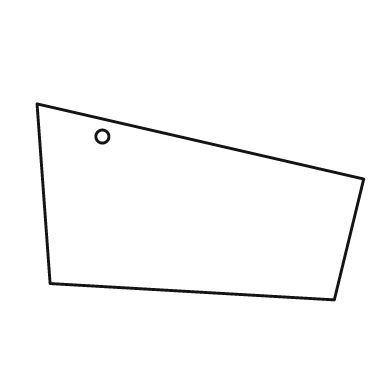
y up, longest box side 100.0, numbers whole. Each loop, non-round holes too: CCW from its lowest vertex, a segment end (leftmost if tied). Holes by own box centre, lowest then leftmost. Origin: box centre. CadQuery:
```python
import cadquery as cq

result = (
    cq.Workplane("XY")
    .moveTo(41.0, -30.0)
    .lineTo(50.0, 7.0)
    .lineTo(-50.0, 30.0)
    .lineTo(-46.0, -25.0)
    .close()
    .moveTo(-30.0, 20.0)
    .circle(2.0)
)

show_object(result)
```